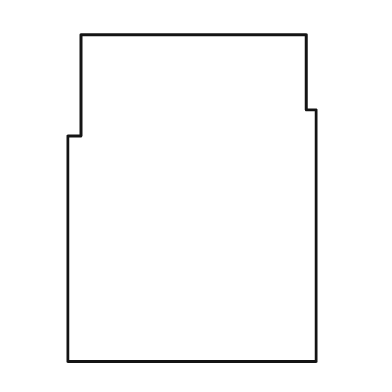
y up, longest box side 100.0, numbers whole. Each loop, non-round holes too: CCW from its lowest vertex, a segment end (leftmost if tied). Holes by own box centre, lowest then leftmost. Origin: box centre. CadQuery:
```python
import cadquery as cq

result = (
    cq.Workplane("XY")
    .moveTo(-38.0, -50.0)
    .lineTo(38.0, -50.0)
    .lineTo(38.0, 27.0)
    .lineTo(35.0, 27.0)
    .lineTo(35.0, 50.0)
    .lineTo(-34.0, 50.0)
    .lineTo(-34.0, 19.0)
    .lineTo(-38.0, 19.0)
    .close()
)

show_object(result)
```